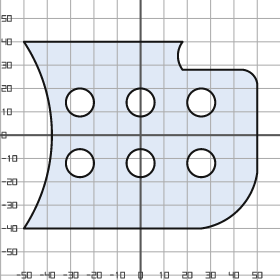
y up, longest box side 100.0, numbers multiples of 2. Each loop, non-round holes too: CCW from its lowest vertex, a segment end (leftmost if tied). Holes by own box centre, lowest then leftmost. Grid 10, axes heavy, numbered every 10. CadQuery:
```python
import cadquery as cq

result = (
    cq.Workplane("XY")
    .moveTo(-50.0, -40.0)
    .lineTo(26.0, -40.0)
    .threePointArc((42.0, -32.0), (50.0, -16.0))
    .lineTo(50.0, 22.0)
    .threePointArc((48.0, 26.0), (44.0, 28.0))
    .lineTo(18.0, 28.0)
    .threePointArc((16.0, 34.0), (18.0, 40.0))
    .lineTo(-50.0, 40.0)
    .threePointArc((-38.0, 0.0), (-50.0, -40.0))
    .close()
    .moveTo(-26.0, -12.0)
    .circle(6.0)
    .moveTo(0.0, -12.0)
    .circle(6.0)
    .moveTo(26.0, -12.0)
    .circle(6.0)
    .moveTo(-26.0, 14.0)
    .circle(6.0)
    .moveTo(0.0, 14.0)
    .circle(6.0)
    .moveTo(26.0, 14.0)
    .circle(6.0)
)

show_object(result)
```